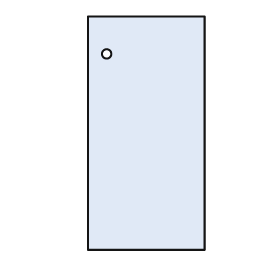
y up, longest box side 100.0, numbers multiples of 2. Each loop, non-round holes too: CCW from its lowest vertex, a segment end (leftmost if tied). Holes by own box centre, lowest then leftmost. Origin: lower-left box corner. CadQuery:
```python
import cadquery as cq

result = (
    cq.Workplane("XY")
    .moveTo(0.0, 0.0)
    .lineTo(50.0, 0.0)
    .lineTo(50.0, 100.0)
    .lineTo(0.0, 100.0)
    .close()
    .moveTo(8.0, 84.0)
    .circle(2.0)
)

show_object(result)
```